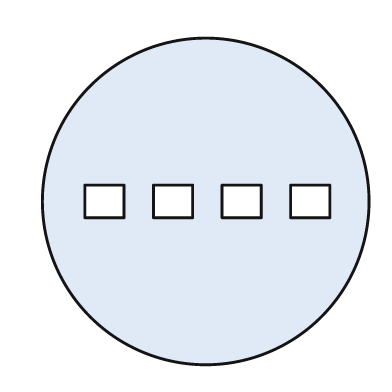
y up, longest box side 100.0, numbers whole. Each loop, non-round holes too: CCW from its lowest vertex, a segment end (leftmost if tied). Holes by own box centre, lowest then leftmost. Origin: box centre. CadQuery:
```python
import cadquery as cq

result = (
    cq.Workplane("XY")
    .moveTo(0.0, 0.0)
    .circle(50.0)
    .moveTo(-37.0, -5.0)
    .lineTo(-25.0, -5.0)
    .lineTo(-25.0, 5.0)
    .lineTo(-37.0, 5.0)
    .close()
    .moveTo(-16.0, -5.0)
    .lineTo(-4.0, -5.0)
    .lineTo(-4.0, 5.0)
    .lineTo(-16.0, 5.0)
    .close()
    .moveTo(5.0, -5.0)
    .lineTo(17.0, -5.0)
    .lineTo(17.0, 5.0)
    .lineTo(5.0, 5.0)
    .close()
    .moveTo(26.0, -5.0)
    .lineTo(38.0, -5.0)
    .lineTo(38.0, 5.0)
    .lineTo(26.0, 5.0)
    .close()
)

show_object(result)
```